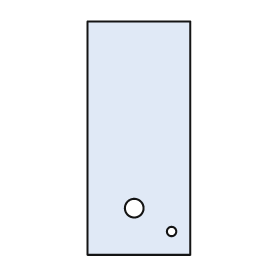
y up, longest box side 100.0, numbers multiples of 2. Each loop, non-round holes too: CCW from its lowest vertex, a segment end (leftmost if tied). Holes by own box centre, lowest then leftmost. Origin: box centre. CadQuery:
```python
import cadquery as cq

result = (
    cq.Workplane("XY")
    .moveTo(-22.0, -50.0)
    .lineTo(22.0, -50.0)
    .lineTo(22.0, 50.0)
    .lineTo(-22.0, 50.0)
    .close()
    .moveTo(14.0, -40.0)
    .circle(2.0)
    .moveTo(-2.0, -30.0)
    .circle(4.0)
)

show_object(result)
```